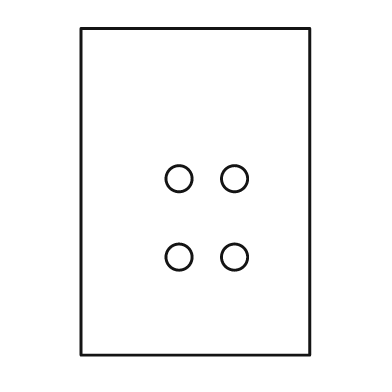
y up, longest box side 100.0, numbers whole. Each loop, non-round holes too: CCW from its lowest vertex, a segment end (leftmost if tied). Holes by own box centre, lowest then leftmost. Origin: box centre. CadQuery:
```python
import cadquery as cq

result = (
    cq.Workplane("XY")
    .moveTo(-35.0, -50.0)
    .lineTo(35.0, -50.0)
    .lineTo(35.0, 50.0)
    .lineTo(-35.0, 50.0)
    .close()
    .moveTo(-5.0, -20.0)
    .circle(4.0)
    .moveTo(12.0, -20.0)
    .circle(4.0)
    .moveTo(-5.0, 4.0)
    .circle(4.0)
    .moveTo(12.0, 4.0)
    .circle(4.0)
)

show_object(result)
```